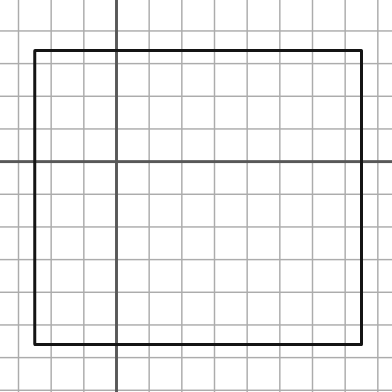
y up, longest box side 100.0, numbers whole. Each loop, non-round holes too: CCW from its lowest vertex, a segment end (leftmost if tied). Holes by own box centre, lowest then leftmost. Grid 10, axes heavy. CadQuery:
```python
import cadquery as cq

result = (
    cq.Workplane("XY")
    .moveTo(-25.0, -56.0)
    .lineTo(75.0, -56.0)
    .lineTo(75.0, 34.0)
    .lineTo(-25.0, 34.0)
    .close()
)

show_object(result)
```